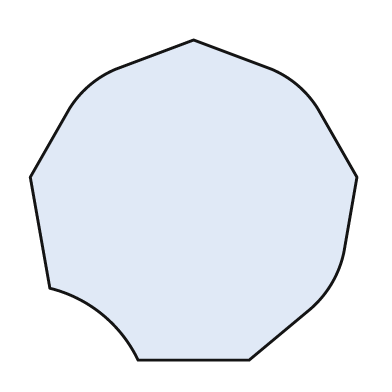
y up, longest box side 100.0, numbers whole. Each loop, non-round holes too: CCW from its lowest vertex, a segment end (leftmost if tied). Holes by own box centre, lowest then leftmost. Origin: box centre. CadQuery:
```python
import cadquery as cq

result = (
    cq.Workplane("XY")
    .moveTo(-17.0, -49.0)
    .lineTo(17.0, -49.0)
    .lineTo(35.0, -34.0)
    .threePointArc((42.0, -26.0), (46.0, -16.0))
    .lineTo(50.0, 7.0)
    .lineTo(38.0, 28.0)
    .threePointArc((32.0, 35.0), (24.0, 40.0))
    .lineTo(0.0, 49.0)
    .lineTo(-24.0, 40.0)
    .threePointArc((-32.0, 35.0), (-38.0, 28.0))
    .lineTo(-50.0, 7.0)
    .lineTo(-44.0, -27.0)
    .threePointArc((-28.0, -35.0), (-17.0, -49.0))
    .close()
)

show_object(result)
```